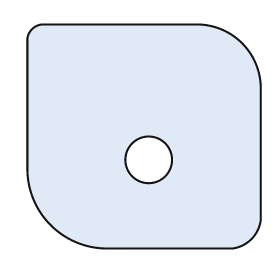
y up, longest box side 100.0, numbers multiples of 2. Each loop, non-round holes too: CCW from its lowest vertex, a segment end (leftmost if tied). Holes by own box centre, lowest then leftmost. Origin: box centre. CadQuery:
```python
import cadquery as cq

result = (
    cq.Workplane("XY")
    .moveTo(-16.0, -48.0)
    .lineTo(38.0, -48.0)
    .threePointArc((46.0, -44.0), (50.0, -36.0))
    .lineTo(50.0, 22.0)
    .threePointArc((42.0, 40.0), (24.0, 48.0))
    .lineTo(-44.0, 48.0)
    .threePointArc((-48.0, 46.0), (-50.0, 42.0))
    .lineTo(-50.0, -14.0)
    .threePointArc((-40.0, -38.0), (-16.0, -48.0))
    .close()
    .moveTo(2.0, -10.0)
    .circle(10.0)
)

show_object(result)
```